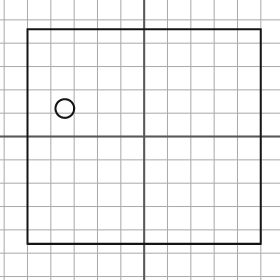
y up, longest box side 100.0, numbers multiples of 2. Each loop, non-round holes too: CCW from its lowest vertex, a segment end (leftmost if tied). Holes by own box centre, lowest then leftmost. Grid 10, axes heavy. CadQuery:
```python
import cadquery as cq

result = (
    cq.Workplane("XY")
    .moveTo(-50.0, -46.0)
    .lineTo(50.0, -46.0)
    .lineTo(50.0, 46.0)
    .lineTo(-50.0, 46.0)
    .close()
    .moveTo(-34.0, 12.0)
    .circle(4.0)
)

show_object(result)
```